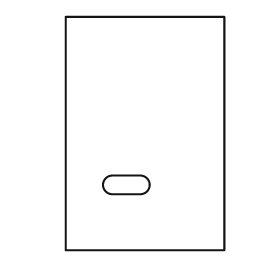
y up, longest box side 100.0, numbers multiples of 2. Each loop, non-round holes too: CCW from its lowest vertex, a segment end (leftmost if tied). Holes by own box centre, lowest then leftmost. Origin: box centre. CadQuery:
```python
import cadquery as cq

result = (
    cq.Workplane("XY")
    .moveTo(-34.0, -50.0)
    .lineTo(34.0, -50.0)
    .lineTo(34.0, 50.0)
    .lineTo(-34.0, 50.0)
    .close()
    .moveTo(-14.0, -26.0)
    .lineTo(-2.0, -26.0)
    .threePointArc((2.0, -22.0), (-2.0, -18.0))
    .lineTo(-14.0, -18.0)
    .threePointArc((-18.0, -22.0), (-14.0, -26.0))
    .close()
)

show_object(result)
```